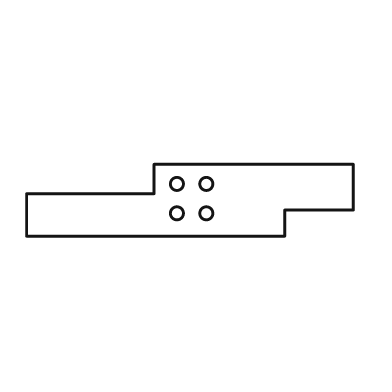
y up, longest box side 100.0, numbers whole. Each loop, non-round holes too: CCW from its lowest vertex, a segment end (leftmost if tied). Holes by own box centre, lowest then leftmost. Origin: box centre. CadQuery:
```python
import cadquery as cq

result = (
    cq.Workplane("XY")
    .moveTo(-50.0, -11.0)
    .lineTo(29.0, -11.0)
    .lineTo(29.0, -3.0)
    .lineTo(50.0, -3.0)
    .lineTo(50.0, 11.0)
    .lineTo(-11.0, 11.0)
    .lineTo(-11.0, 2.0)
    .lineTo(-50.0, 2.0)
    .close()
    .moveTo(-4.0, -4.0)
    .circle(2.0)
    .moveTo(5.0, -4.0)
    .circle(2.0)
    .moveTo(-4.0, 5.0)
    .circle(2.0)
    .moveTo(5.0, 5.0)
    .circle(2.0)
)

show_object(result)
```